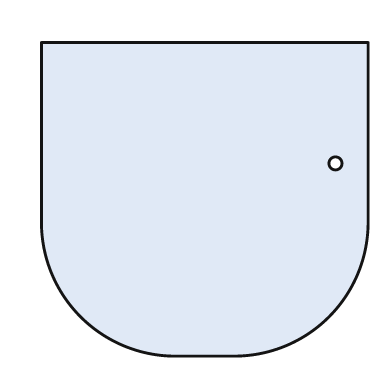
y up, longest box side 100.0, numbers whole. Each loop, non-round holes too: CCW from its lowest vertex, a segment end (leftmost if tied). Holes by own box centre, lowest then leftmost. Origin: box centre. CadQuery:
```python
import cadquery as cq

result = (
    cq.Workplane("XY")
    .moveTo(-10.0, -48.0)
    .lineTo(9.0, -48.0)
    .threePointArc((38.0, -36.0), (50.0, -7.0))
    .lineTo(50.0, 48.0)
    .lineTo(-50.0, 48.0)
    .lineTo(-50.0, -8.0)
    .threePointArc((-38.0, -36.0), (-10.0, -48.0))
    .close()
    .moveTo(40.0, 11.0)
    .circle(2.0)
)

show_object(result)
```